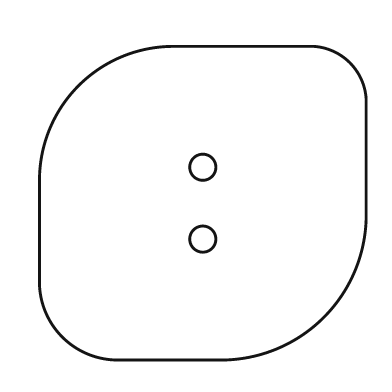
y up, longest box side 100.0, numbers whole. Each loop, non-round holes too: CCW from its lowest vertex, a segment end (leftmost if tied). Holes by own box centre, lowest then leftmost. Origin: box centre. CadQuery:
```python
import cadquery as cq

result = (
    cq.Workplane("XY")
    .moveTo(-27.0, -48.0)
    .lineTo(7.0, -48.0)
    .threePointArc((37.0, -35.0), (50.0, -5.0))
    .lineTo(50.0, 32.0)
    .threePointArc((45.0, 43.0), (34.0, 48.0))
    .lineTo(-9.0, 48.0)
    .threePointArc((-38.0, 36.0), (-50.0, 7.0))
    .lineTo(-50.0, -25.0)
    .threePointArc((-43.0, -41.0), (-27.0, -48.0))
    .close()
    .moveTo(0.0, -11.0)
    .circle(4.0)
    .moveTo(0.0, 11.0)
    .circle(4.0)
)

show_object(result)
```